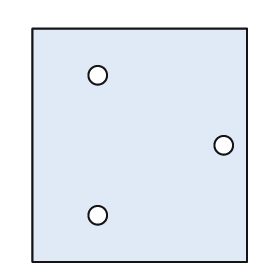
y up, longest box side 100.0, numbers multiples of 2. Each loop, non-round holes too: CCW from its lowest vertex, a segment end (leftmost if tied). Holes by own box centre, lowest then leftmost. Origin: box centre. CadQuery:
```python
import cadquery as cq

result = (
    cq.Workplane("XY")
    .moveTo(-46.0, -50.0)
    .lineTo(46.0, -50.0)
    .lineTo(46.0, 50.0)
    .lineTo(-46.0, 50.0)
    .close()
    .moveTo(-18.0, -30.0)
    .circle(4.0)
    .moveTo(36.0, 0.0)
    .circle(4.0)
    .moveTo(-18.0, 30.0)
    .circle(4.0)
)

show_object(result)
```